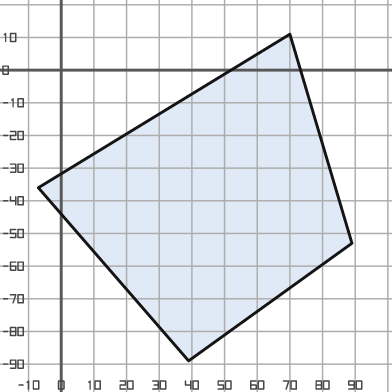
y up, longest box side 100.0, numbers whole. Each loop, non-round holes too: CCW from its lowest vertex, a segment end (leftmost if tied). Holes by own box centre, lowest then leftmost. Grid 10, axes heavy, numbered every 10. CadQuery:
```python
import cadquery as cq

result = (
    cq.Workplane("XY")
    .moveTo(39.0, -89.0)
    .lineTo(89.0, -53.0)
    .lineTo(70.0, 11.0)
    .lineTo(-7.0, -36.0)
    .close()
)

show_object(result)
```